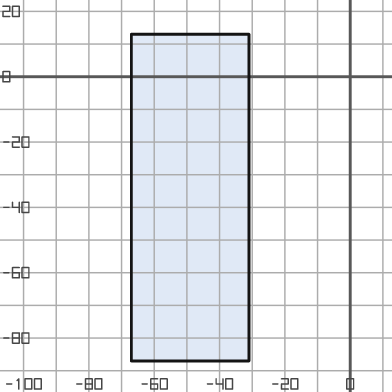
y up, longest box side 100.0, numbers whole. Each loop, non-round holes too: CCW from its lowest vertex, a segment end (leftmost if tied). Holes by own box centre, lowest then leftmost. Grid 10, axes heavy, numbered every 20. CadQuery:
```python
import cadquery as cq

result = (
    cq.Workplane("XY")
    .moveTo(-67.0, -87.0)
    .lineTo(-31.0, -87.0)
    .lineTo(-31.0, 13.0)
    .lineTo(-67.0, 13.0)
    .close()
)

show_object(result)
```